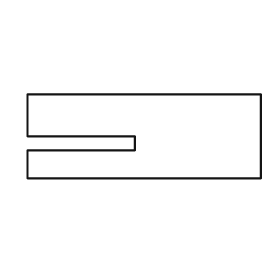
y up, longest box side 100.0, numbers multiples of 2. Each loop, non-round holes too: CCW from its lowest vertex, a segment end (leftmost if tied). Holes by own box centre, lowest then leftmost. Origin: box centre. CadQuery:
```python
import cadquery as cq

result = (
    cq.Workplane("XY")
    .moveTo(-50.0, -18.0)
    .lineTo(50.0, -18.0)
    .lineTo(50.0, 18.0)
    .lineTo(-50.0, 18.0)
    .lineTo(-50.0, 0.0)
    .lineTo(-4.0, 0.0)
    .lineTo(-4.0, -6.0)
    .lineTo(-50.0, -6.0)
    .close()
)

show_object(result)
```